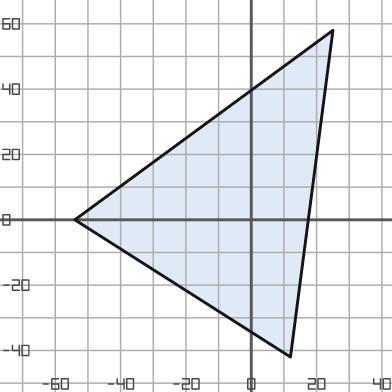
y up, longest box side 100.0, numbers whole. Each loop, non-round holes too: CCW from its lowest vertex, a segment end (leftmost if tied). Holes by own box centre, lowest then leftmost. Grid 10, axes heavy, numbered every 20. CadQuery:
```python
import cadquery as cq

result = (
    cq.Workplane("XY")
    .moveTo(12.0, -42.0)
    .lineTo(25.0, 58.0)
    .lineTo(-54.0, 0.0)
    .close()
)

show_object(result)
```